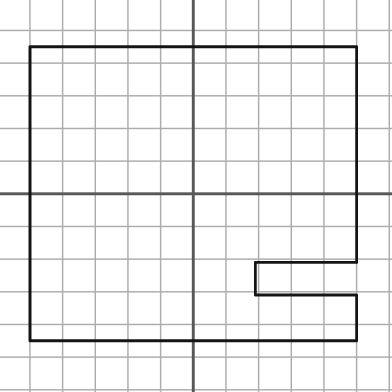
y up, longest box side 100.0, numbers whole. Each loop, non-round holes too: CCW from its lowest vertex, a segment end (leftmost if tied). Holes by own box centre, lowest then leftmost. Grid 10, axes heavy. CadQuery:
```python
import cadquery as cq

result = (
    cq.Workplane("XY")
    .moveTo(-50.0, -45.0)
    .lineTo(50.0, -45.0)
    .lineTo(50.0, -31.0)
    .lineTo(19.0, -31.0)
    .lineTo(19.0, -21.0)
    .lineTo(50.0, -21.0)
    .lineTo(50.0, 45.0)
    .lineTo(-50.0, 45.0)
    .close()
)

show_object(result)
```